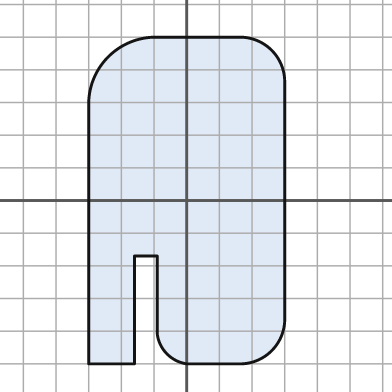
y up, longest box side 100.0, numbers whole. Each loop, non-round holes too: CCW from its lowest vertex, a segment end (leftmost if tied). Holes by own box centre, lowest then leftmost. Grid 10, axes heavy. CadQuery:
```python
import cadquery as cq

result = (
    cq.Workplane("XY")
    .moveTo(-30.0, -50.0)
    .lineTo(-16.0, -50.0)
    .lineTo(-16.0, -17.0)
    .lineTo(-9.0, -17.0)
    .lineTo(-9.0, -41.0)
    .threePointArc((-6.0, -47.0), (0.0, -50.0))
    .lineTo(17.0, -50.0)
    .threePointArc((26.0, -46.0), (30.0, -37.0))
    .lineTo(30.0, 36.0)
    .threePointArc((26.0, 46.0), (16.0, 50.0))
    .lineTo(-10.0, 50.0)
    .threePointArc((-24.0, 44.0), (-30.0, 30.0))
    .close()
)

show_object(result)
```